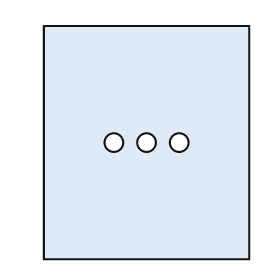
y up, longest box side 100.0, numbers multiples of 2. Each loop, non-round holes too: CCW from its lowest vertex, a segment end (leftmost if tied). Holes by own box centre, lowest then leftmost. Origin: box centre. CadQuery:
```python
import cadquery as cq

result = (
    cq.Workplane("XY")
    .moveTo(-44.0, -50.0)
    .lineTo(44.0, -50.0)
    .lineTo(44.0, 50.0)
    .lineTo(-44.0, 50.0)
    .close()
    .moveTo(-14.0, 0.0)
    .circle(4.0)
    .moveTo(0.0, 0.0)
    .circle(4.0)
    .moveTo(14.0, 0.0)
    .circle(4.0)
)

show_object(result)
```